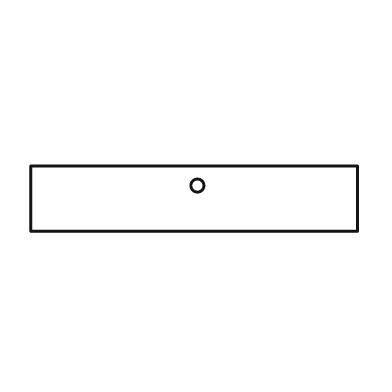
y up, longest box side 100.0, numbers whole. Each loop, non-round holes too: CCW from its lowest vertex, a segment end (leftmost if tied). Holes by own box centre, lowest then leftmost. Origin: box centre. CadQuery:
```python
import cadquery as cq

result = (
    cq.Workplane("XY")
    .moveTo(-50.0, -10.0)
    .lineTo(50.0, -10.0)
    .lineTo(50.0, 10.0)
    .lineTo(-50.0, 10.0)
    .close()
    .moveTo(1.0, 4.0)
    .circle(2.0)
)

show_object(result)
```